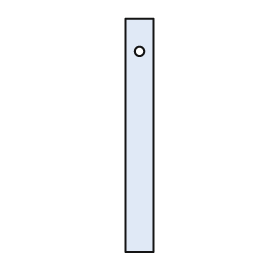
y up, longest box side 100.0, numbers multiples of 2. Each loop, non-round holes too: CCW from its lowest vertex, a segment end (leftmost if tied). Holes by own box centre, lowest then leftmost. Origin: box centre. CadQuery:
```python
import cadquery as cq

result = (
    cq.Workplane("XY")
    .moveTo(-6.0, -50.0)
    .lineTo(6.0, -50.0)
    .lineTo(6.0, 50.0)
    .lineTo(-6.0, 50.0)
    .close()
    .moveTo(0.0, 36.0)
    .circle(2.0)
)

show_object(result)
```